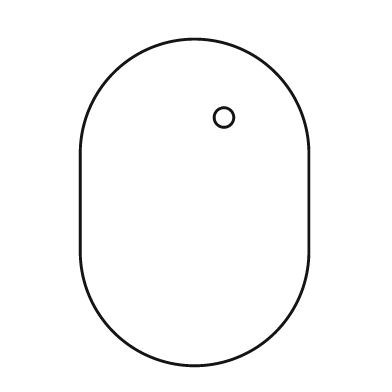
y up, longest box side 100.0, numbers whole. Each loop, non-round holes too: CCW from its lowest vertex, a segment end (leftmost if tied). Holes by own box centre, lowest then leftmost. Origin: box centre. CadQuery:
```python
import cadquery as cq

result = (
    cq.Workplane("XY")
    .moveTo(-35.0, -15.0)
    .threePointArc((0.0, -50.0), (35.0, -15.0))
    .lineTo(35.0, 15.0)
    .threePointArc((0.0, 50.0), (-35.0, 15.0))
    .close()
    .moveTo(9.0, 26.0)
    .circle(3.0)
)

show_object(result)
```